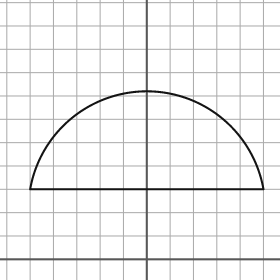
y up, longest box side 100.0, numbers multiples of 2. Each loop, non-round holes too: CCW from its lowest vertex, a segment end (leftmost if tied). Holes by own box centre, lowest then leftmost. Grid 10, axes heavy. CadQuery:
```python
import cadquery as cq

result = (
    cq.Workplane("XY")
    .moveTo(-50.0, 30.0)
    .lineTo(50.0, 30.0)
    .threePointArc((0.0, 72.0), (-50.0, 30.0))
    .close()
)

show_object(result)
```